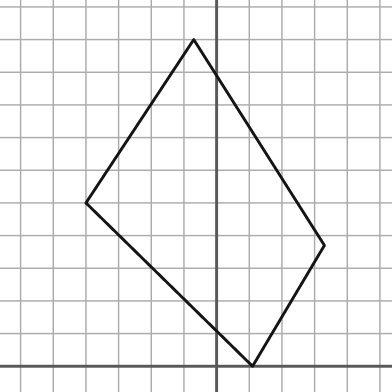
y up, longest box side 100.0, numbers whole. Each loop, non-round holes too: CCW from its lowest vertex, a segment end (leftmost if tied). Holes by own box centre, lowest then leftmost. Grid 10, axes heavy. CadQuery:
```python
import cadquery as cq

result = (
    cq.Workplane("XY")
    .moveTo(11.0, 0.0)
    .lineTo(33.0, 37.0)
    .lineTo(-7.0, 100.0)
    .lineTo(-40.0, 50.0)
    .close()
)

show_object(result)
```